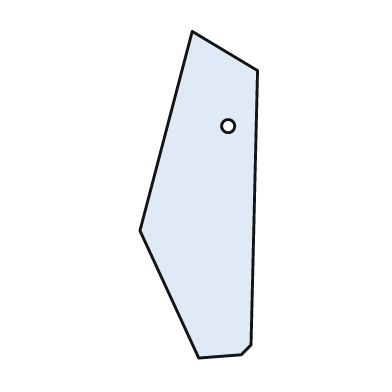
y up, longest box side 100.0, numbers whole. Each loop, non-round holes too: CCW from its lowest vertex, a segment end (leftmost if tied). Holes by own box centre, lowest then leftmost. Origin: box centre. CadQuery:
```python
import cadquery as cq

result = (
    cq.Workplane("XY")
    .moveTo(0.0, -50.0)
    .lineTo(13.0, -49.0)
    .lineTo(16.0, -46.0)
    .lineTo(18.0, 38.0)
    .lineTo(-2.0, 50.0)
    .lineTo(-18.0, -11.0)
    .close()
    .moveTo(9.0, 21.0)
    .circle(2.0)
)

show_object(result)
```